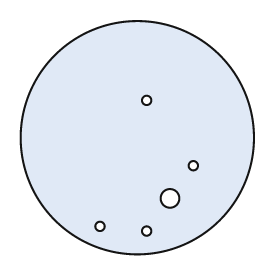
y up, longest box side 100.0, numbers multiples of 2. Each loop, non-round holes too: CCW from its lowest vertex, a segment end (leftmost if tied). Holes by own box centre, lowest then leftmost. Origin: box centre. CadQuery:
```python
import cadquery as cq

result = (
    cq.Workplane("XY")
    .moveTo(0.0, 0.0)
    .circle(50.0)
    .moveTo(4.0, -40.0)
    .circle(2.0)
    .moveTo(-16.0, -38.0)
    .circle(2.0)
    .moveTo(14.0, -26.0)
    .circle(4.0)
    .moveTo(24.0, -12.0)
    .circle(2.0)
    .moveTo(4.0, 16.0)
    .circle(2.0)
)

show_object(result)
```